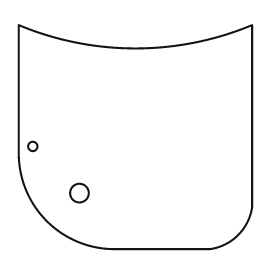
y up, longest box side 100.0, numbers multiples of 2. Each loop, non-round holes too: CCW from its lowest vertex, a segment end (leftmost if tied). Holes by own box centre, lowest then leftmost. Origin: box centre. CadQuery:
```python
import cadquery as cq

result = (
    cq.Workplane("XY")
    .moveTo(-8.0, -48.0)
    .lineTo(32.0, -48.0)
    .threePointArc((44.0, -42.0), (50.0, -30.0))
    .lineTo(50.0, 48.0)
    .threePointArc((0.0, 38.0), (-50.0, 48.0))
    .lineTo(-50.0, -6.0)
    .threePointArc((-38.0, -36.0), (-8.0, -48.0))
    .close()
    .moveTo(-24.0, -24.0)
    .circle(4.0)
    .moveTo(-44.0, -4.0)
    .circle(2.0)
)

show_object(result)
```